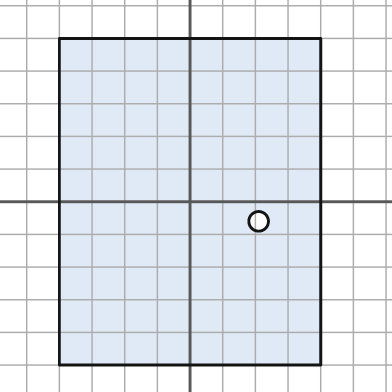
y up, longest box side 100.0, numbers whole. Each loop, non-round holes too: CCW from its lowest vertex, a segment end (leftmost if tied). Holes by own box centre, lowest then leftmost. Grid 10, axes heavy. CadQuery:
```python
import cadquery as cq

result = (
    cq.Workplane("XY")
    .moveTo(-40.0, -50.0)
    .lineTo(40.0, -50.0)
    .lineTo(40.0, 50.0)
    .lineTo(-40.0, 50.0)
    .close()
    .moveTo(21.0, -6.0)
    .circle(3.0)
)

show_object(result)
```